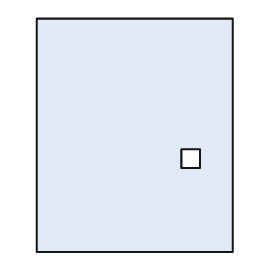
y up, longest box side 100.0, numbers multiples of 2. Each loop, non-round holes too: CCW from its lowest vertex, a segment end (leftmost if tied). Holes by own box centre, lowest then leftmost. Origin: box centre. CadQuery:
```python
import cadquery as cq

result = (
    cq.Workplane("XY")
    .moveTo(-42.0, -50.0)
    .lineTo(42.0, -50.0)
    .lineTo(42.0, 50.0)
    .lineTo(-42.0, 50.0)
    .close()
    .moveTo(20.0, -14.0)
    .lineTo(28.0, -14.0)
    .lineTo(28.0, -6.0)
    .lineTo(20.0, -6.0)
    .close()
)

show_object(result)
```